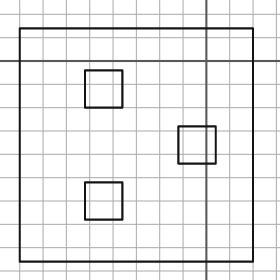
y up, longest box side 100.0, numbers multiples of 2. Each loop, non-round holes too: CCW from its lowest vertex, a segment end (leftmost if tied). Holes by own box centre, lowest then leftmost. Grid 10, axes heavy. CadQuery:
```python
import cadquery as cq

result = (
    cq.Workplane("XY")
    .moveTo(-80.0, -86.0)
    .lineTo(20.0, -86.0)
    .lineTo(20.0, 14.0)
    .lineTo(-80.0, 14.0)
    .close()
    .moveTo(-52.0, -68.0)
    .lineTo(-36.0, -68.0)
    .lineTo(-36.0, -52.0)
    .lineTo(-52.0, -52.0)
    .close()
    .moveTo(-12.0, -44.0)
    .lineTo(4.0, -44.0)
    .lineTo(4.0, -28.0)
    .lineTo(-12.0, -28.0)
    .close()
    .moveTo(-52.0, -20.0)
    .lineTo(-36.0, -20.0)
    .lineTo(-36.0, -4.0)
    .lineTo(-52.0, -4.0)
    .close()
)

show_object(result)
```